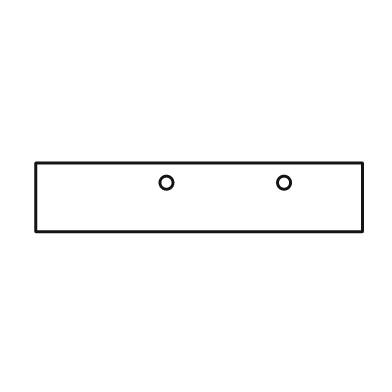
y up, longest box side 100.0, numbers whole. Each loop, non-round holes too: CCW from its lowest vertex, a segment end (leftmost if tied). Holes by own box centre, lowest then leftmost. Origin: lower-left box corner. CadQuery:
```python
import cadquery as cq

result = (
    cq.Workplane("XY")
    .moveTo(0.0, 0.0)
    .lineTo(100.0, 0.0)
    .lineTo(100.0, 21.0)
    .lineTo(0.0, 21.0)
    .close()
    .moveTo(40.0, 15.0)
    .circle(2.0)
    .moveTo(76.0, 15.0)
    .circle(2.0)
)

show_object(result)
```